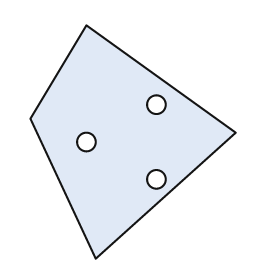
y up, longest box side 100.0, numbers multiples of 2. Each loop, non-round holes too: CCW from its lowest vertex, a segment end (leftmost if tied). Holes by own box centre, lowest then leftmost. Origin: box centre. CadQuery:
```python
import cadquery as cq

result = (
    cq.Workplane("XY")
    .moveTo(-16.0, -50.0)
    .lineTo(44.0, 4.0)
    .lineTo(-20.0, 50.0)
    .lineTo(-44.0, 10.0)
    .close()
    .moveTo(10.0, -16.0)
    .circle(4.0)
    .moveTo(-20.0, 0.0)
    .circle(4.0)
    .moveTo(10.0, 16.0)
    .circle(4.0)
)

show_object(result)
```